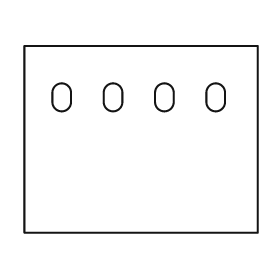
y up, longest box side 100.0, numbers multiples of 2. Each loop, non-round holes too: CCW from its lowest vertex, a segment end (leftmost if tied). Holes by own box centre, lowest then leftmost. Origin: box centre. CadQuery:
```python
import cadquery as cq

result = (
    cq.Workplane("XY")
    .moveTo(-50.0, -40.0)
    .lineTo(50.0, -40.0)
    .lineTo(50.0, 40.0)
    .lineTo(-50.0, 40.0)
    .close()
    .moveTo(-38.0, 16.0)
    .threePointArc((-34.0, 12.0), (-30.0, 16.0))
    .lineTo(-30.0, 20.0)
    .threePointArc((-34.0, 24.0), (-38.0, 20.0))
    .close()
    .moveTo(-16.0, 16.0)
    .threePointArc((-12.0, 12.0), (-8.0, 16.0))
    .lineTo(-8.0, 20.0)
    .threePointArc((-12.0, 24.0), (-16.0, 20.0))
    .close()
    .moveTo(6.0, 16.0)
    .threePointArc((10.0, 12.0), (14.0, 16.0))
    .lineTo(14.0, 20.0)
    .threePointArc((10.0, 24.0), (6.0, 20.0))
    .close()
    .moveTo(28.0, 16.0)
    .threePointArc((32.0, 12.0), (36.0, 16.0))
    .lineTo(36.0, 20.0)
    .threePointArc((32.0, 24.0), (28.0, 20.0))
    .close()
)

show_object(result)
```